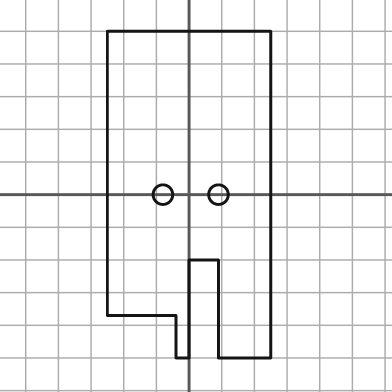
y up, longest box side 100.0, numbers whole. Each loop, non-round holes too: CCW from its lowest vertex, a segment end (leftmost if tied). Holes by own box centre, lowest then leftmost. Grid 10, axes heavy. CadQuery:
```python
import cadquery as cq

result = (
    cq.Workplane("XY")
    .moveTo(-4.0, -50.0)
    .lineTo(0.0, -50.0)
    .lineTo(0.0, -20.0)
    .lineTo(9.0, -20.0)
    .lineTo(9.0, -50.0)
    .lineTo(25.0, -50.0)
    .lineTo(25.0, 50.0)
    .lineTo(-25.0, 50.0)
    .lineTo(-25.0, -37.0)
    .lineTo(-4.0, -37.0)
    .close()
    .moveTo(-8.0, 0.0)
    .circle(3.0)
    .moveTo(9.0, 0.0)
    .circle(3.0)
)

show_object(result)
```